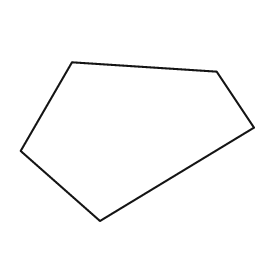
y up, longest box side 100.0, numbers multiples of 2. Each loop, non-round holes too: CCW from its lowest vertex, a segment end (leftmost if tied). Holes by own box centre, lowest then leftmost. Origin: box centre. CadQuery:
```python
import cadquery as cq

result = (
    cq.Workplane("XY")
    .moveTo(-16.0, -34.0)
    .lineTo(50.0, 6.0)
    .lineTo(34.0, 30.0)
    .lineTo(-28.0, 34.0)
    .lineTo(-50.0, -4.0)
    .close()
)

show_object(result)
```